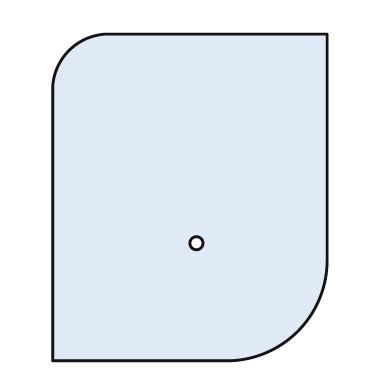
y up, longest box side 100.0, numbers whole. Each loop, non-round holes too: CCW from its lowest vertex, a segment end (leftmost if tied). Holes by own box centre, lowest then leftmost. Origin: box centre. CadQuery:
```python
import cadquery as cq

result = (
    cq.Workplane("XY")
    .moveTo(-42.0, -50.0)
    .lineTo(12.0, -50.0)
    .threePointArc((33.0, -41.0), (42.0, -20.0))
    .lineTo(42.0, 50.0)
    .lineTo(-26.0, 50.0)
    .threePointArc((-37.0, 45.0), (-42.0, 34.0))
    .close()
    .moveTo(2.0, -14.0)
    .circle(2.0)
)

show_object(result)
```